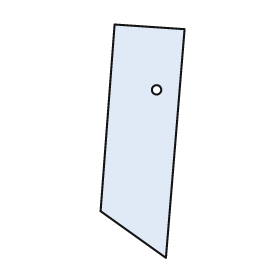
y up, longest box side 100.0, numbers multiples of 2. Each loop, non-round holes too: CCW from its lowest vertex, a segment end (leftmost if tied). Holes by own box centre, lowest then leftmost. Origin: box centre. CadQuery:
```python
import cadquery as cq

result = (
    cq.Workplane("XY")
    .moveTo(10.0, -50.0)
    .lineTo(18.0, 48.0)
    .lineTo(-12.0, 50.0)
    .lineTo(-18.0, -30.0)
    .close()
    .moveTo(6.0, 22.0)
    .circle(2.0)
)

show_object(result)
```